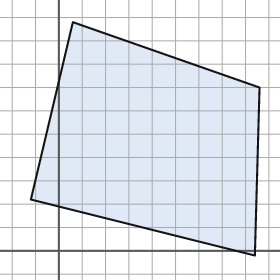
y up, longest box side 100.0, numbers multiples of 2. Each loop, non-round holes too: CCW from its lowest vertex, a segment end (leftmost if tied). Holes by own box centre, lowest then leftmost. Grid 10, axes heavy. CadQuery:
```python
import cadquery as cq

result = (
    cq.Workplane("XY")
    .moveTo(84.0, -2.0)
    .lineTo(86.0, 70.0)
    .lineTo(6.0, 98.0)
    .lineTo(-12.0, 22.0)
    .close()
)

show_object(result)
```